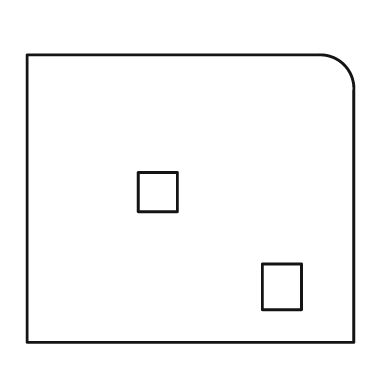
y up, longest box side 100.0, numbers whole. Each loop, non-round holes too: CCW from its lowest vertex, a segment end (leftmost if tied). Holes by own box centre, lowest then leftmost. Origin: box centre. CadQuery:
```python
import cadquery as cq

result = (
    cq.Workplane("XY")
    .moveTo(-50.0, -44.0)
    .lineTo(50.0, -44.0)
    .lineTo(50.0, 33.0)
    .threePointArc((47.0, 41.0), (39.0, 44.0))
    .lineTo(-50.0, 44.0)
    .close()
    .moveTo(22.0, -34.0)
    .lineTo(34.0, -34.0)
    .lineTo(34.0, -20.0)
    .lineTo(22.0, -20.0)
    .close()
    .moveTo(-16.0, -4.0)
    .lineTo(-4.0, -4.0)
    .lineTo(-4.0, 8.0)
    .lineTo(-16.0, 8.0)
    .close()
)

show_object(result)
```